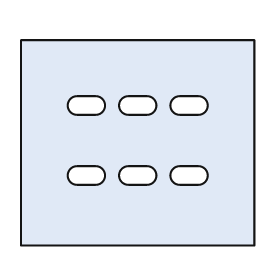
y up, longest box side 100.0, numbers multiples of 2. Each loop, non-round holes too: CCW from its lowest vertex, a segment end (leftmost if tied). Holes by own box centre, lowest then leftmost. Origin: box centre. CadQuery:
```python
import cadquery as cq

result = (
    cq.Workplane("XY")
    .moveTo(-50.0, -44.0)
    .lineTo(50.0, -44.0)
    .lineTo(50.0, 44.0)
    .lineTo(-50.0, 44.0)
    .close()
    .moveTo(-26.0, -18.0)
    .lineTo(-18.0, -18.0)
    .threePointArc((-14.0, -14.0), (-18.0, -10.0))
    .lineTo(-26.0, -10.0)
    .threePointArc((-30.0, -14.0), (-26.0, -18.0))
    .close()
    .moveTo(-4.0, -18.0)
    .lineTo(4.0, -18.0)
    .threePointArc((8.0, -14.0), (4.0, -10.0))
    .lineTo(-4.0, -10.0)
    .threePointArc((-8.0, -14.0), (-4.0, -18.0))
    .close()
    .moveTo(18.0, -18.0)
    .lineTo(26.0, -18.0)
    .threePointArc((30.0, -14.0), (26.0, -10.0))
    .lineTo(18.0, -10.0)
    .threePointArc((14.0, -14.0), (18.0, -18.0))
    .close()
    .moveTo(-26.0, 12.0)
    .lineTo(-18.0, 12.0)
    .threePointArc((-14.0, 16.0), (-18.0, 20.0))
    .lineTo(-26.0, 20.0)
    .threePointArc((-30.0, 16.0), (-26.0, 12.0))
    .close()
    .moveTo(-4.0, 12.0)
    .lineTo(4.0, 12.0)
    .threePointArc((8.0, 16.0), (4.0, 20.0))
    .lineTo(-4.0, 20.0)
    .threePointArc((-8.0, 16.0), (-4.0, 12.0))
    .close()
    .moveTo(18.0, 12.0)
    .lineTo(26.0, 12.0)
    .threePointArc((30.0, 16.0), (26.0, 20.0))
    .lineTo(18.0, 20.0)
    .threePointArc((14.0, 16.0), (18.0, 12.0))
    .close()
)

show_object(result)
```